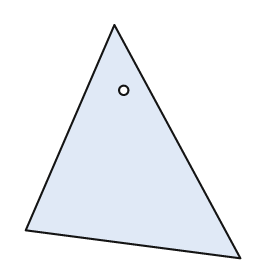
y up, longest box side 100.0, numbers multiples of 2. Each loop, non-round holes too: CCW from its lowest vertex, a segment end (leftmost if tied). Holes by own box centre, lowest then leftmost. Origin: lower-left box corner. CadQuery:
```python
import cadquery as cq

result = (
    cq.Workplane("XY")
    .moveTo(92.0, 0.0)
    .lineTo(38.0, 100.0)
    .lineTo(0.0, 12.0)
    .close()
    .moveTo(42.0, 72.0)
    .circle(2.0)
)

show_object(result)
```